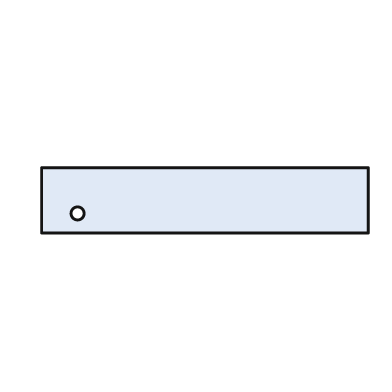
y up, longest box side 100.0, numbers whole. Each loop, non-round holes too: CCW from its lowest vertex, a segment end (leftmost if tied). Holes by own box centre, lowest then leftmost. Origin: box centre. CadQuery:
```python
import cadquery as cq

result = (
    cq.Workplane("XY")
    .moveTo(-50.0, -10.0)
    .lineTo(50.0, -10.0)
    .lineTo(50.0, 10.0)
    .lineTo(-50.0, 10.0)
    .close()
    .moveTo(-39.0, -4.0)
    .circle(2.0)
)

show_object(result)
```